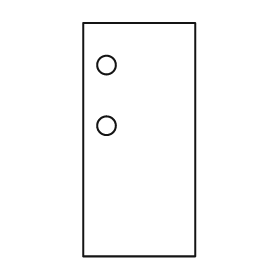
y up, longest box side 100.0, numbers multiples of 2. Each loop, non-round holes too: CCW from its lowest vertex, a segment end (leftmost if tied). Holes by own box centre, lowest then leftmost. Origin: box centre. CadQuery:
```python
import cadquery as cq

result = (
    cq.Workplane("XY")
    .moveTo(-24.0, -50.0)
    .lineTo(24.0, -50.0)
    .lineTo(24.0, 50.0)
    .lineTo(-24.0, 50.0)
    .close()
    .moveTo(-14.0, 6.0)
    .circle(4.0)
    .moveTo(-14.0, 32.0)
    .circle(4.0)
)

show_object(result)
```